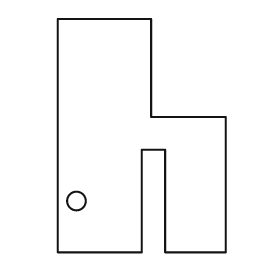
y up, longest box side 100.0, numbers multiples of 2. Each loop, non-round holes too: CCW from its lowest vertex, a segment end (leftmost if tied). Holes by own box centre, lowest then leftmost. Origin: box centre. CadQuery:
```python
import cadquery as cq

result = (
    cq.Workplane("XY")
    .moveTo(-36.0, -50.0)
    .lineTo(0.0, -50.0)
    .lineTo(0.0, -6.0)
    .lineTo(10.0, -6.0)
    .lineTo(10.0, -50.0)
    .lineTo(36.0, -50.0)
    .lineTo(36.0, 8.0)
    .lineTo(4.0, 8.0)
    .lineTo(4.0, 50.0)
    .lineTo(-36.0, 50.0)
    .close()
    .moveTo(-28.0, -28.0)
    .circle(4.0)
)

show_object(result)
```